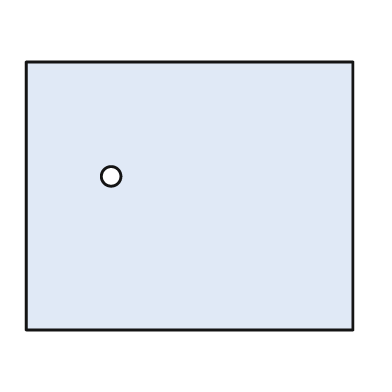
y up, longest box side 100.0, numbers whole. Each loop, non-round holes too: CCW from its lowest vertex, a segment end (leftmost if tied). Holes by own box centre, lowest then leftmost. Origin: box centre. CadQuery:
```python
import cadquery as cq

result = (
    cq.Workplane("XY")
    .moveTo(-50.0, -41.0)
    .lineTo(50.0, -41.0)
    .lineTo(50.0, 41.0)
    .lineTo(-50.0, 41.0)
    .close()
    .moveTo(-24.0, 6.0)
    .circle(3.0)
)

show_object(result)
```